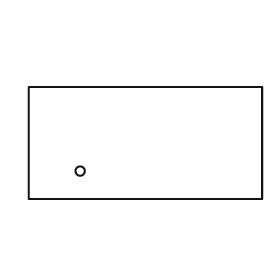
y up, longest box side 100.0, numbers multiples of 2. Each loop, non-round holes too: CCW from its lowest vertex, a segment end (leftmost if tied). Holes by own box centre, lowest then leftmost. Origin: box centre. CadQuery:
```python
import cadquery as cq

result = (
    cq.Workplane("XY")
    .moveTo(-50.0, -24.0)
    .lineTo(50.0, -24.0)
    .lineTo(50.0, 24.0)
    .lineTo(-50.0, 24.0)
    .close()
    .moveTo(-28.0, -12.0)
    .circle(2.0)
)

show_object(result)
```